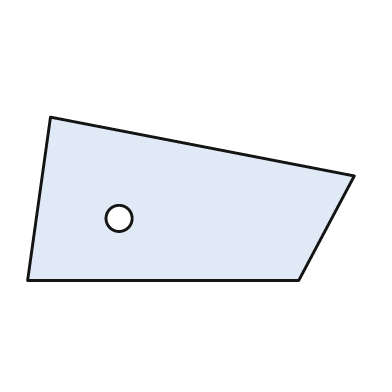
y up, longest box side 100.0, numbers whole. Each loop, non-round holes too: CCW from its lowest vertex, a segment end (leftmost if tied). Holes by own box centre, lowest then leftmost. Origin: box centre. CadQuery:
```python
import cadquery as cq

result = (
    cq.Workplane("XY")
    .moveTo(-50.0, -25.0)
    .lineTo(33.0, -25.0)
    .lineTo(50.0, 7.0)
    .lineTo(-43.0, 25.0)
    .close()
    .moveTo(-22.0, -6.0)
    .circle(4.0)
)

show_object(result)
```